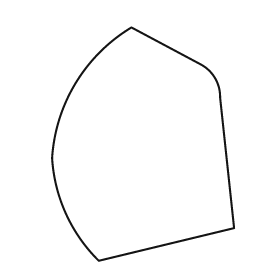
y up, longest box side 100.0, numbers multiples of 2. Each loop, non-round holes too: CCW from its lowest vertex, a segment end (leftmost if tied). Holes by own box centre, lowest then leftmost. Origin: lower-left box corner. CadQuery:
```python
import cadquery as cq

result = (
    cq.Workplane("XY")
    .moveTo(20.0, 0.0)
    .lineTo(78.0, 14.0)
    .lineTo(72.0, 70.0)
    .threePointArc((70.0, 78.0), (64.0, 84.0))
    .lineTo(34.0, 100.0)
    .threePointArc((10.0, 76.0), (0.0, 44.0))
    .threePointArc((6.0, 20.0), (20.0, 0.0))
    .close()
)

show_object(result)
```